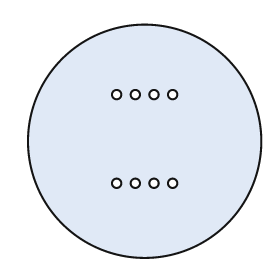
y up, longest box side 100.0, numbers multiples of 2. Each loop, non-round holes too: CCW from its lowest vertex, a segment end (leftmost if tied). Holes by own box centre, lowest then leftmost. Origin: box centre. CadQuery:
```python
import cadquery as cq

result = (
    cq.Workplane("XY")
    .moveTo(0.0, 0.0)
    .circle(50.0)
    .moveTo(-12.0, -18.0)
    .circle(2.0)
    .moveTo(-4.0, -18.0)
    .circle(2.0)
    .moveTo(4.0, -18.0)
    .circle(2.0)
    .moveTo(12.0, -18.0)
    .circle(2.0)
    .moveTo(-12.0, 20.0)
    .circle(2.0)
    .moveTo(-4.0, 20.0)
    .circle(2.0)
    .moveTo(4.0, 20.0)
    .circle(2.0)
    .moveTo(12.0, 20.0)
    .circle(2.0)
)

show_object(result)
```